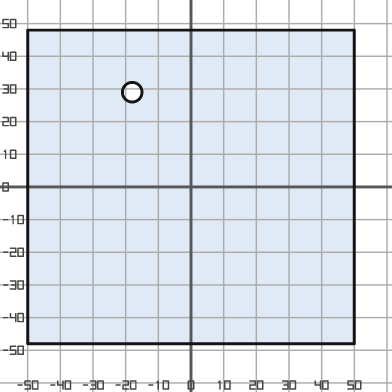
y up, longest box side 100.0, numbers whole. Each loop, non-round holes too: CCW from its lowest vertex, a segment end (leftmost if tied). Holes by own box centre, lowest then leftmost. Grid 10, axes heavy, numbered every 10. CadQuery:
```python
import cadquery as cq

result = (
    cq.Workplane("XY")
    .moveTo(-50.0, -48.0)
    .lineTo(50.0, -48.0)
    .lineTo(50.0, 48.0)
    .lineTo(-50.0, 48.0)
    .close()
    .moveTo(-18.0, 29.0)
    .circle(3.0)
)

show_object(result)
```